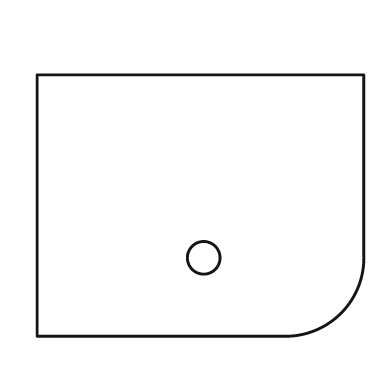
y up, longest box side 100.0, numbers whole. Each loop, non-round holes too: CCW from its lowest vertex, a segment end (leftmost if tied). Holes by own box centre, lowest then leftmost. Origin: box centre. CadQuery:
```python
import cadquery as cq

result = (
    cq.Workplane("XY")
    .moveTo(-50.0, -40.0)
    .lineTo(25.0, -40.0)
    .threePointArc((43.0, -33.0), (50.0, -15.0))
    .lineTo(50.0, 40.0)
    .lineTo(-50.0, 40.0)
    .close()
    .moveTo(1.0, -16.0)
    .circle(5.0)
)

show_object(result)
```